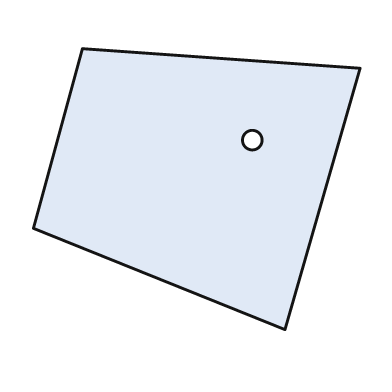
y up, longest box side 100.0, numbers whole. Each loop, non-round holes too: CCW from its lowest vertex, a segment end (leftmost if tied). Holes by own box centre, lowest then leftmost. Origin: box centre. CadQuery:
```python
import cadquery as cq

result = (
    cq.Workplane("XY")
    .moveTo(27.0, -43.0)
    .lineTo(50.0, 37.0)
    .lineTo(-35.0, 43.0)
    .lineTo(-50.0, -12.0)
    .close()
    .moveTo(17.0, 15.0)
    .circle(3.0)
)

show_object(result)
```